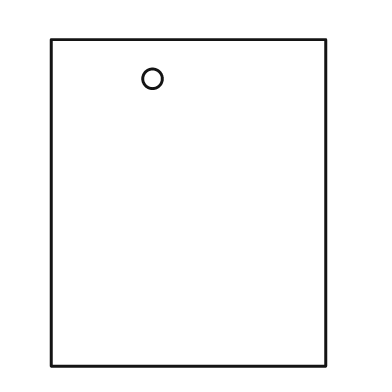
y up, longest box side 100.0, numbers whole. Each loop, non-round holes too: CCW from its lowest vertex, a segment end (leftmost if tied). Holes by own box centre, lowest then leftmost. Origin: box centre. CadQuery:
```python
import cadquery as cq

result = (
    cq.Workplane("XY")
    .moveTo(-42.0, -50.0)
    .lineTo(42.0, -50.0)
    .lineTo(42.0, 50.0)
    .lineTo(-42.0, 50.0)
    .close()
    .moveTo(-11.0, 38.0)
    .circle(3.0)
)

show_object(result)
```